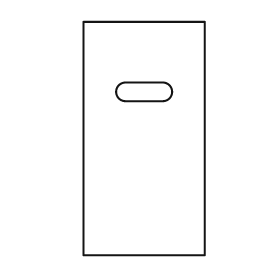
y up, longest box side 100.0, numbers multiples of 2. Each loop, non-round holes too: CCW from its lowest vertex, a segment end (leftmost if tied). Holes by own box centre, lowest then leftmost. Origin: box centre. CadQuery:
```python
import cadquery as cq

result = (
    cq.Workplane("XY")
    .moveTo(-26.0, -50.0)
    .lineTo(26.0, -50.0)
    .lineTo(26.0, 50.0)
    .lineTo(-26.0, 50.0)
    .close()
    .moveTo(-8.0, 16.0)
    .lineTo(8.0, 16.0)
    .threePointArc((12.0, 20.0), (8.0, 24.0))
    .lineTo(-8.0, 24.0)
    .threePointArc((-12.0, 20.0), (-8.0, 16.0))
    .close()
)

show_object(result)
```